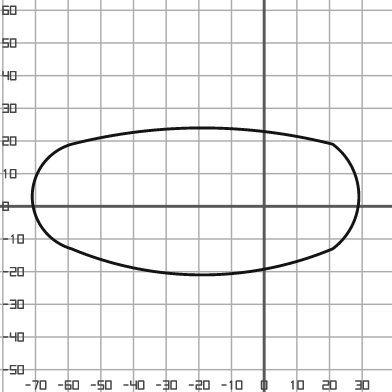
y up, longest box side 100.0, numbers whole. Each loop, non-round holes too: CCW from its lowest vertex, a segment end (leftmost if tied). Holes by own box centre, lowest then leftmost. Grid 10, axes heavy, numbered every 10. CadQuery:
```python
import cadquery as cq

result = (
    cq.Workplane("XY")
    .moveTo(-59.0, -13.0)
    .threePointArc((-19.0, -21.0), (21.0, -13.0))
    .threePointArc((29.0, 3.0), (21.0, 19.0))
    .threePointArc((-19.0, 24.0), (-59.0, 19.0))
    .threePointArc((-71.0, 3.0), (-59.0, -13.0))
    .close()
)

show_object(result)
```